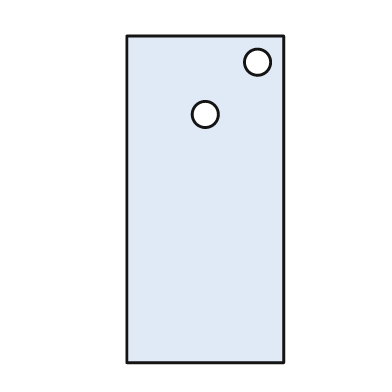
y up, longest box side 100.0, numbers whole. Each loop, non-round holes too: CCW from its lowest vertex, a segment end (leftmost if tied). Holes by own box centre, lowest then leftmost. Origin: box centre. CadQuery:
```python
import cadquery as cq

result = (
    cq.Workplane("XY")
    .moveTo(-24.0, -50.0)
    .lineTo(24.0, -50.0)
    .lineTo(24.0, 50.0)
    .lineTo(-24.0, 50.0)
    .close()
    .moveTo(0.0, 26.0)
    .circle(4.0)
    .moveTo(16.0, 42.0)
    .circle(4.0)
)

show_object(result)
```